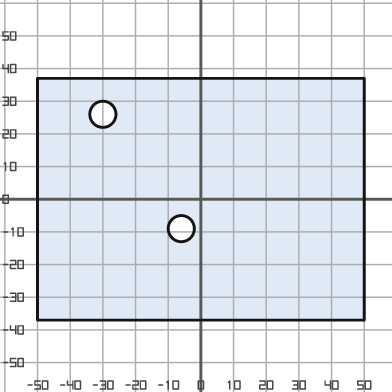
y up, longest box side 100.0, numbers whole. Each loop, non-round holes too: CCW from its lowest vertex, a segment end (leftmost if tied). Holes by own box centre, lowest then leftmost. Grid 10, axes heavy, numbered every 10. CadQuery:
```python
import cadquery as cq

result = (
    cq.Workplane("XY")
    .moveTo(-50.0, -37.0)
    .lineTo(50.0, -37.0)
    .lineTo(50.0, 37.0)
    .lineTo(-50.0, 37.0)
    .close()
    .moveTo(-6.0, -9.0)
    .circle(4.0)
    .moveTo(-30.0, 26.0)
    .circle(4.0)
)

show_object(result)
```